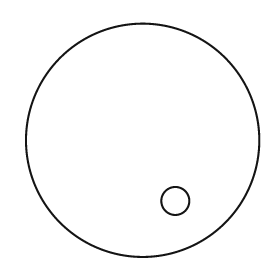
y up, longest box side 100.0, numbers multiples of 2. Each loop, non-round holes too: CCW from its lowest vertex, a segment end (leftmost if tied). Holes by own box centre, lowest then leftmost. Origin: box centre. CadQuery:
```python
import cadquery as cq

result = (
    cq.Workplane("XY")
    .moveTo(0.0, 0.0)
    .circle(50.0)
    .moveTo(14.0, -26.0)
    .circle(6.0)
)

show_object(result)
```